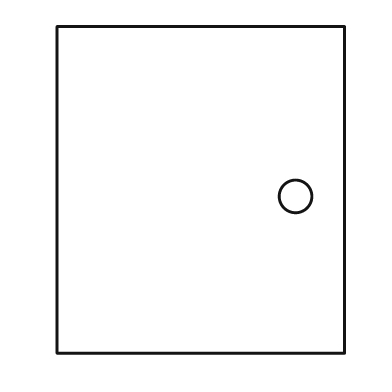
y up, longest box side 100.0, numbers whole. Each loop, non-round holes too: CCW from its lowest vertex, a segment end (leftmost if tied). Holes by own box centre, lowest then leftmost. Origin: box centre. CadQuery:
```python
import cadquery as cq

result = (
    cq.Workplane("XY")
    .moveTo(-44.0, -50.0)
    .lineTo(44.0, -50.0)
    .lineTo(44.0, 50.0)
    .lineTo(-44.0, 50.0)
    .close()
    .moveTo(29.0, -2.0)
    .circle(5.0)
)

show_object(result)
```